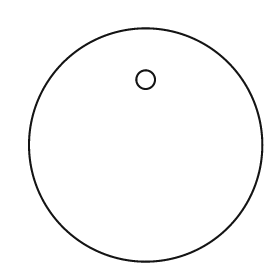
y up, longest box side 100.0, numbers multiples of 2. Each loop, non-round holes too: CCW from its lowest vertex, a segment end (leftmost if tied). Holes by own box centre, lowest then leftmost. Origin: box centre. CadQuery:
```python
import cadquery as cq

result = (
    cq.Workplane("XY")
    .moveTo(0.0, 0.0)
    .circle(50.0)
    .moveTo(0.0, 28.0)
    .circle(4.0)
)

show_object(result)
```